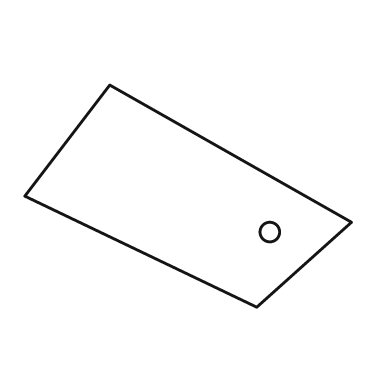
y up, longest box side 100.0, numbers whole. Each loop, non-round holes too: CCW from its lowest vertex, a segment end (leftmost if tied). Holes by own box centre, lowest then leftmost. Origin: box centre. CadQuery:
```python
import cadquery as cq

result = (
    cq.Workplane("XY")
    .moveTo(21.0, -34.0)
    .lineTo(50.0, -8.0)
    .lineTo(-24.0, 34.0)
    .lineTo(-50.0, 0.0)
    .close()
    .moveTo(25.0, -11.0)
    .circle(3.0)
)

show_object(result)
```